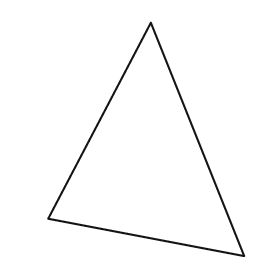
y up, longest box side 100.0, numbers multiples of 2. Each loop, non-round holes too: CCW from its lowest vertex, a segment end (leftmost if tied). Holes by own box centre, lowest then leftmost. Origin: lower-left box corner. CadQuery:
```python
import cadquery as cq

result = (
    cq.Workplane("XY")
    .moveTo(84.0, 0.0)
    .lineTo(44.0, 100.0)
    .lineTo(0.0, 16.0)
    .close()
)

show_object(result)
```